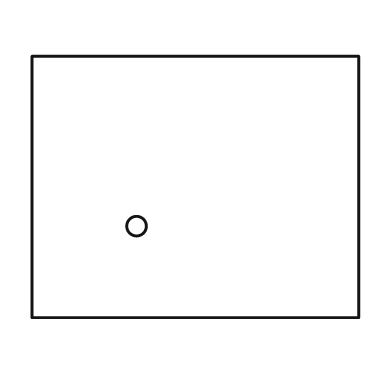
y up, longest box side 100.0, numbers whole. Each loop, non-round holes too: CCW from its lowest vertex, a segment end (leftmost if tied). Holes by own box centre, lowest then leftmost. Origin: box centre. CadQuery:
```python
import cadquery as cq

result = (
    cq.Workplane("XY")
    .moveTo(-50.0, -40.0)
    .lineTo(50.0, -40.0)
    .lineTo(50.0, 40.0)
    .lineTo(-50.0, 40.0)
    .close()
    .moveTo(-18.0, -12.0)
    .circle(3.0)
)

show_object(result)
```